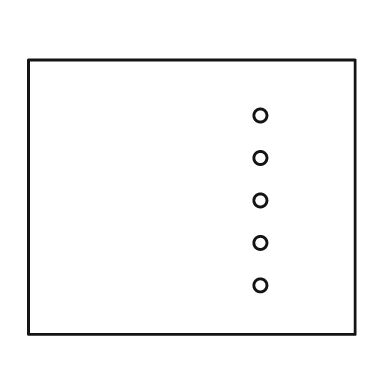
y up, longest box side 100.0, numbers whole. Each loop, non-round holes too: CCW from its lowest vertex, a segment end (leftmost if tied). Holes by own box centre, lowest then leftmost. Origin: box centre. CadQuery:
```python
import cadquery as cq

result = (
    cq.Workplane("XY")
    .moveTo(-50.0, -42.0)
    .lineTo(50.0, -42.0)
    .lineTo(50.0, 42.0)
    .lineTo(-50.0, 42.0)
    .close()
    .moveTo(21.0, -27.0)
    .circle(2.0)
    .moveTo(21.0, -14.0)
    .circle(2.0)
    .moveTo(21.0, -1.0)
    .circle(2.0)
    .moveTo(21.0, 12.0)
    .circle(2.0)
    .moveTo(21.0, 25.0)
    .circle(2.0)
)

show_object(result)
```